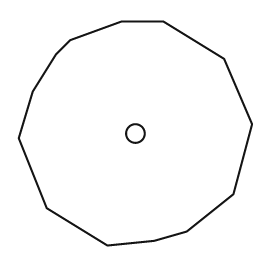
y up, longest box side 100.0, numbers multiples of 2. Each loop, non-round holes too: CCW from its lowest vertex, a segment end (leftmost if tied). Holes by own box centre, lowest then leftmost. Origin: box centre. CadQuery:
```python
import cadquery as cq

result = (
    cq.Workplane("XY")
    .moveTo(-12.0, -48.0)
    .lineTo(8.0, -46.0)
    .lineTo(22.0, -42.0)
    .lineTo(42.0, -26.0)
    .lineTo(50.0, 4.0)
    .lineTo(38.0, 32.0)
    .lineTo(12.0, 48.0)
    .lineTo(-6.0, 48.0)
    .lineTo(-28.0, 40.0)
    .lineTo(-34.0, 34.0)
    .lineTo(-44.0, 18.0)
    .lineTo(-50.0, -2.0)
    .lineTo(-38.0, -32.0)
    .close()
    .moveTo(0.0, 0.0)
    .circle(4.0)
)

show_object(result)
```